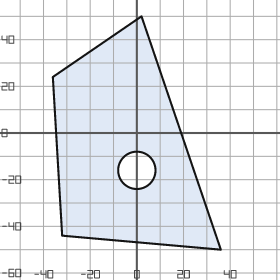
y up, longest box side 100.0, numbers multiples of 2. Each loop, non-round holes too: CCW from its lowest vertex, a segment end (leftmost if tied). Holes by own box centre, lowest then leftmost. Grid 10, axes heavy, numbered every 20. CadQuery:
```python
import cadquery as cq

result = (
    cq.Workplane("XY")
    .moveTo(36.0, -50.0)
    .lineTo(2.0, 50.0)
    .lineTo(-36.0, 24.0)
    .lineTo(-32.0, -44.0)
    .close()
    .moveTo(0.0, -16.0)
    .circle(8.0)
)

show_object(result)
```